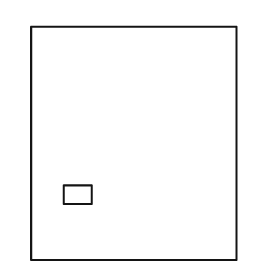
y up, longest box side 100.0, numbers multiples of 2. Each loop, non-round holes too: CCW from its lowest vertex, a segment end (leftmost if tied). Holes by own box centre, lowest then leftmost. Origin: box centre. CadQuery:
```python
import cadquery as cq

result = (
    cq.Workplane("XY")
    .moveTo(-44.0, -50.0)
    .lineTo(44.0, -50.0)
    .lineTo(44.0, 50.0)
    .lineTo(-44.0, 50.0)
    .close()
    .moveTo(-30.0, -26.0)
    .lineTo(-18.0, -26.0)
    .lineTo(-18.0, -18.0)
    .lineTo(-30.0, -18.0)
    .close()
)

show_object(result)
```